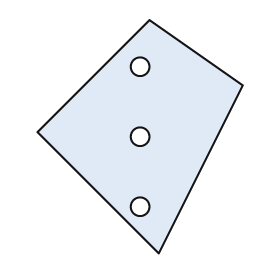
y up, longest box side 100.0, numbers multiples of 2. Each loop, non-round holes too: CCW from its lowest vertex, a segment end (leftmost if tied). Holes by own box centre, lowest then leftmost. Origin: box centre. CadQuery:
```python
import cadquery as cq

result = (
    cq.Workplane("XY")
    .moveTo(8.0, -50.0)
    .lineTo(44.0, 22.0)
    .lineTo(4.0, 50.0)
    .lineTo(-44.0, 2.0)
    .close()
    .moveTo(0.0, -30.0)
    .circle(4.0)
    .moveTo(0.0, 0.0)
    .circle(4.0)
    .moveTo(0.0, 30.0)
    .circle(4.0)
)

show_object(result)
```